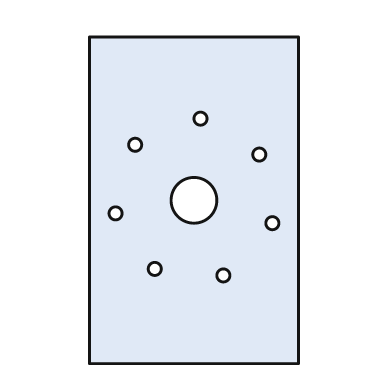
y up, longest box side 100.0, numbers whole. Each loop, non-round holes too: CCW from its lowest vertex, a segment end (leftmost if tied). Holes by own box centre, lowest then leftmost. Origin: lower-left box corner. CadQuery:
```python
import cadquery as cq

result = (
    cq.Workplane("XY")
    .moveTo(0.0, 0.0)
    .lineTo(64.0, 0.0)
    .lineTo(64.0, 100.0)
    .lineTo(0.0, 100.0)
    .close()
    .moveTo(41.0, 27.0)
    .circle(2.0)
    .moveTo(20.0, 29.0)
    .circle(2.0)
    .moveTo(56.0, 43.0)
    .circle(2.0)
    .moveTo(8.0, 46.0)
    .circle(2.0)
    .moveTo(32.0, 50.0)
    .circle(7.0)
    .moveTo(52.0, 64.0)
    .circle(2.0)
    .moveTo(14.0, 67.0)
    .circle(2.0)
    .moveTo(34.0, 75.0)
    .circle(2.0)
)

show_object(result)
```